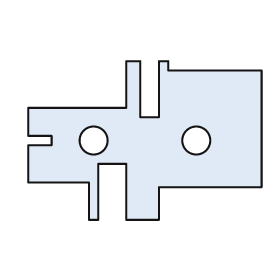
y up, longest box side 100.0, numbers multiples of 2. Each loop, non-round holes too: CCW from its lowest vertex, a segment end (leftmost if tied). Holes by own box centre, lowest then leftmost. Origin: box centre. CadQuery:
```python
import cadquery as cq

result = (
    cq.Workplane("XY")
    .moveTo(-24.0, -34.0)
    .lineTo(-20.0, -34.0)
    .lineTo(-20.0, -10.0)
    .lineTo(-8.0, -10.0)
    .lineTo(-8.0, -34.0)
    .lineTo(6.0, -34.0)
    .lineTo(6.0, -20.0)
    .lineTo(50.0, -20.0)
    .lineTo(50.0, 30.0)
    .lineTo(10.0, 30.0)
    .lineTo(10.0, 34.0)
    .lineTo(6.0, 34.0)
    .lineTo(6.0, 10.0)
    .lineTo(-2.0, 10.0)
    .lineTo(-2.0, 34.0)
    .lineTo(-8.0, 34.0)
    .lineTo(-8.0, 14.0)
    .lineTo(-50.0, 14.0)
    .lineTo(-50.0, 2.0)
    .lineTo(-40.0, 2.0)
    .lineTo(-40.0, -2.0)
    .lineTo(-50.0, -2.0)
    .lineTo(-50.0, -18.0)
    .lineTo(-24.0, -18.0)
    .close()
    .moveTo(-22.0, 0.0)
    .circle(6.0)
    .moveTo(22.0, 0.0)
    .circle(6.0)
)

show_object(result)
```